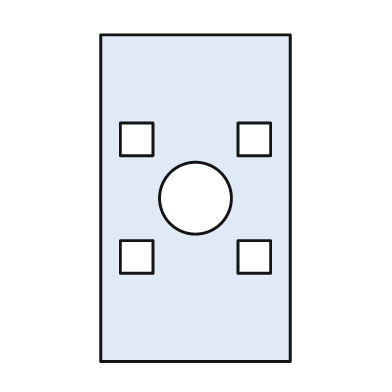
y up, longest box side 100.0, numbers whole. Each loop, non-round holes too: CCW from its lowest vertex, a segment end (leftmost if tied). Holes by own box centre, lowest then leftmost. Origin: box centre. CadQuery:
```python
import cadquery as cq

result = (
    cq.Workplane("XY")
    .moveTo(-29.0, -50.0)
    .lineTo(29.0, -50.0)
    .lineTo(29.0, 50.0)
    .lineTo(-29.0, 50.0)
    .close()
    .moveTo(-23.0, -23.0)
    .lineTo(-13.0, -23.0)
    .lineTo(-13.0, -13.0)
    .lineTo(-23.0, -13.0)
    .close()
    .moveTo(13.0, -23.0)
    .lineTo(23.0, -23.0)
    .lineTo(23.0, -13.0)
    .lineTo(13.0, -13.0)
    .close()
    .moveTo(0.0, 0.0)
    .circle(11.0)
    .moveTo(-23.0, 13.0)
    .lineTo(-13.0, 13.0)
    .lineTo(-13.0, 23.0)
    .lineTo(-23.0, 23.0)
    .close()
    .moveTo(13.0, 13.0)
    .lineTo(23.0, 13.0)
    .lineTo(23.0, 23.0)
    .lineTo(13.0, 23.0)
    .close()
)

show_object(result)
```